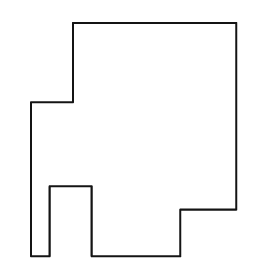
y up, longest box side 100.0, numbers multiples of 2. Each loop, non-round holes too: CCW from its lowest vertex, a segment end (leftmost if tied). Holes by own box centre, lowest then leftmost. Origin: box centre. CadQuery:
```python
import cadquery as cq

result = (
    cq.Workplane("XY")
    .moveTo(-44.0, -50.0)
    .lineTo(-36.0, -50.0)
    .lineTo(-36.0, -20.0)
    .lineTo(-18.0, -20.0)
    .lineTo(-18.0, -50.0)
    .lineTo(20.0, -50.0)
    .lineTo(20.0, -30.0)
    .lineTo(44.0, -30.0)
    .lineTo(44.0, 50.0)
    .lineTo(-26.0, 50.0)
    .lineTo(-26.0, 16.0)
    .lineTo(-44.0, 16.0)
    .close()
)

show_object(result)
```